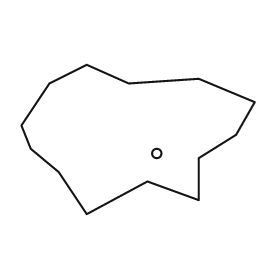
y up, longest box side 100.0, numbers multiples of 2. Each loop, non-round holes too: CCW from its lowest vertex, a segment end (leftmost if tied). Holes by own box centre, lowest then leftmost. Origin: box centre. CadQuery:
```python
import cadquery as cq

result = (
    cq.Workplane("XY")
    .moveTo(-22.0, -32.0)
    .lineTo(4.0, -18.0)
    .lineTo(26.0, -26.0)
    .lineTo(26.0, -8.0)
    .lineTo(42.0, 2.0)
    .lineTo(50.0, 16.0)
    .lineTo(26.0, 26.0)
    .lineTo(-4.0, 24.0)
    .lineTo(-22.0, 32.0)
    .lineTo(-38.0, 24.0)
    .lineTo(-50.0, 6.0)
    .lineTo(-46.0, -4.0)
    .lineTo(-34.0, -14.0)
    .close()
    .moveTo(8.0, -6.0)
    .circle(2.0)
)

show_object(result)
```